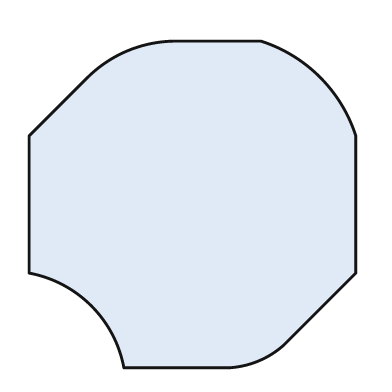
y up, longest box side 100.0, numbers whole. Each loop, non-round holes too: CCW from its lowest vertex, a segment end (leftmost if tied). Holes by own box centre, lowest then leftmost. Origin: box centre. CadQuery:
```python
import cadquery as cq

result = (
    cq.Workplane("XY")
    .moveTo(-21.0, -50.0)
    .lineTo(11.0, -50.0)
    .threePointArc((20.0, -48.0), (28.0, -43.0))
    .lineTo(50.0, -21.0)
    .lineTo(50.0, 21.0)
    .threePointArc((39.0, 39.0), (21.0, 50.0))
    .lineTo(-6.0, 50.0)
    .threePointArc((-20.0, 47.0), (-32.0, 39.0))
    .lineTo(-50.0, 21.0)
    .lineTo(-50.0, -21.0)
    .threePointArc((-31.0, -31.0), (-21.0, -50.0))
    .close()
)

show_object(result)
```